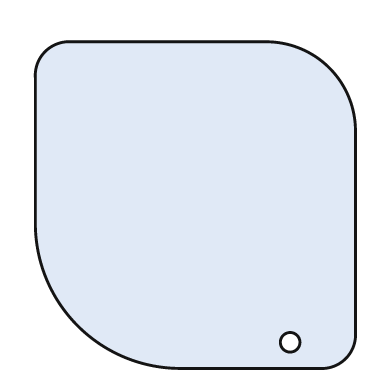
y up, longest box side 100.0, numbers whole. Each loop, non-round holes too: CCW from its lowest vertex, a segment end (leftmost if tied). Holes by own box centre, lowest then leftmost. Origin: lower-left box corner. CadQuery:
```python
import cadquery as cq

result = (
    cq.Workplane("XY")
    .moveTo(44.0, 0.0)
    .lineTo(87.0, 0.0)
    .threePointArc((95.0, 3.0), (98.0, 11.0))
    .lineTo(98.0, 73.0)
    .threePointArc((90.0, 92.0), (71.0, 100.0))
    .lineTo(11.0, 100.0)
    .threePointArc((3.0, 97.0), (0.0, 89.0))
    .lineTo(0.0, 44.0)
    .threePointArc((13.0, 13.0), (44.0, 0.0))
    .close()
    .moveTo(78.0, 8.0)
    .circle(3.0)
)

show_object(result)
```